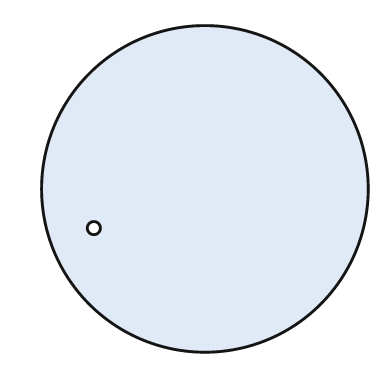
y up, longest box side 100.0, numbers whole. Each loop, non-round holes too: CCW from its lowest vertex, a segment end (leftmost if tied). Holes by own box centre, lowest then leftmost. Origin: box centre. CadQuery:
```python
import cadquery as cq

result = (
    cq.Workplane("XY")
    .moveTo(0.0, 0.0)
    .circle(50.0)
    .moveTo(-34.0, -12.0)
    .circle(2.0)
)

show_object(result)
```